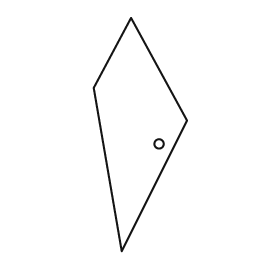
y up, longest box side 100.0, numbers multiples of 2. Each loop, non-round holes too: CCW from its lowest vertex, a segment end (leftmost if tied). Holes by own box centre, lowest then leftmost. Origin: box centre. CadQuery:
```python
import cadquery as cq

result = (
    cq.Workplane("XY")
    .moveTo(-8.0, -50.0)
    .lineTo(20.0, 6.0)
    .lineTo(-4.0, 50.0)
    .lineTo(-20.0, 20.0)
    .close()
    .moveTo(8.0, -4.0)
    .circle(2.0)
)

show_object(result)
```